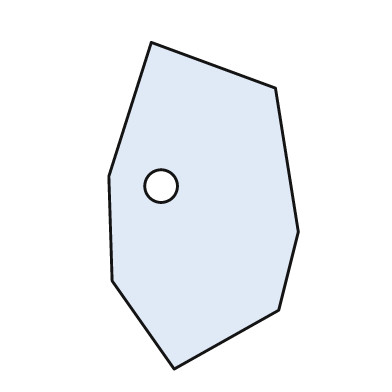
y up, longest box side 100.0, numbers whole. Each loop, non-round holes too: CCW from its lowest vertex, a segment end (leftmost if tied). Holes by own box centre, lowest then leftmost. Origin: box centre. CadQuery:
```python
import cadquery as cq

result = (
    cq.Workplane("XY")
    .moveTo(-9.0, -50.0)
    .lineTo(23.0, -32.0)
    .lineTo(29.0, -8.0)
    .lineTo(22.0, 36.0)
    .lineTo(-16.0, 50.0)
    .lineTo(-29.0, 9.0)
    .lineTo(-28.0, -23.0)
    .close()
    .moveTo(-13.0, 6.0)
    .circle(5.0)
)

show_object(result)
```